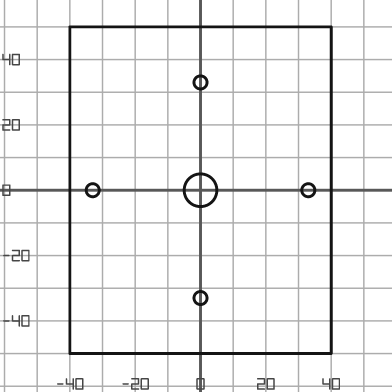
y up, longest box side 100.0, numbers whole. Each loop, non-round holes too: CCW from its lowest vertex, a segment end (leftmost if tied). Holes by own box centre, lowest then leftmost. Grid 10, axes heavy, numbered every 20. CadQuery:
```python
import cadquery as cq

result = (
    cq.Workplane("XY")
    .moveTo(-40.0, -50.0)
    .lineTo(40.0, -50.0)
    .lineTo(40.0, 50.0)
    .lineTo(-40.0, 50.0)
    .close()
    .moveTo(0.0, -33.0)
    .circle(2.0)
    .moveTo(-33.0, 0.0)
    .circle(2.0)
    .moveTo(0.0, 0.0)
    .circle(5.0)
    .moveTo(33.0, 0.0)
    .circle(2.0)
    .moveTo(0.0, 33.0)
    .circle(2.0)
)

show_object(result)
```